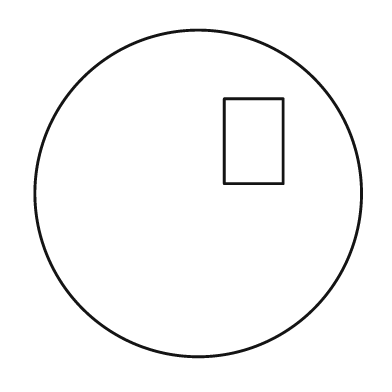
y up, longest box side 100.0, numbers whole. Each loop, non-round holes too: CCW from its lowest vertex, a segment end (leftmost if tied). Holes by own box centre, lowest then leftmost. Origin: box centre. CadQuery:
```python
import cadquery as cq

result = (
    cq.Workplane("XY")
    .moveTo(0.0, 0.0)
    .circle(50.0)
    .moveTo(8.0, 3.0)
    .lineTo(26.0, 3.0)
    .lineTo(26.0, 29.0)
    .lineTo(8.0, 29.0)
    .close()
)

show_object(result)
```